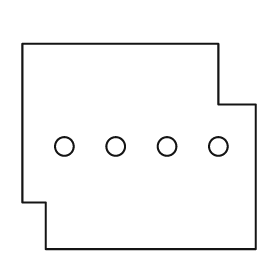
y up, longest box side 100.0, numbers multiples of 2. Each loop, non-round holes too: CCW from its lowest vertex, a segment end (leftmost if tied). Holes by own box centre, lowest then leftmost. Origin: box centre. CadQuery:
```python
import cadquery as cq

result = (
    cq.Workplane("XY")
    .moveTo(-40.0, -44.0)
    .lineTo(50.0, -44.0)
    .lineTo(50.0, 18.0)
    .lineTo(34.0, 18.0)
    .lineTo(34.0, 44.0)
    .lineTo(-50.0, 44.0)
    .lineTo(-50.0, -24.0)
    .lineTo(-40.0, -24.0)
    .close()
    .moveTo(-32.0, 0.0)
    .circle(4.0)
    .moveTo(-10.0, 0.0)
    .circle(4.0)
    .moveTo(12.0, 0.0)
    .circle(4.0)
    .moveTo(34.0, 0.0)
    .circle(4.0)
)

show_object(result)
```